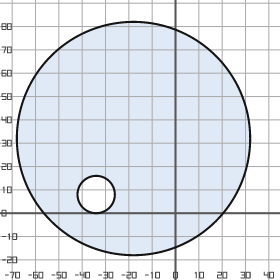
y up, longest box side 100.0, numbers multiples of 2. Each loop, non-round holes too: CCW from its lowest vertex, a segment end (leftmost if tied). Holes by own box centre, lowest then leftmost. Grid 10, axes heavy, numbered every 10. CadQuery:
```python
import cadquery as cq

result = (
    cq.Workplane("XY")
    .moveTo(-18.0, 32.0)
    .circle(50.0)
    .moveTo(-34.0, 8.0)
    .circle(8.0)
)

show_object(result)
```